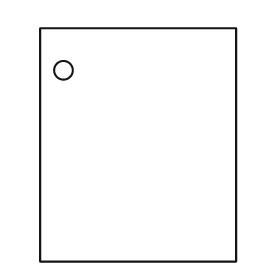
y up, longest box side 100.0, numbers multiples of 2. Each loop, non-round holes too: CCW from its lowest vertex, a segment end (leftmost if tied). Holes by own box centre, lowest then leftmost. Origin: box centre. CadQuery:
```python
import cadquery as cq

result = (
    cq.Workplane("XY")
    .moveTo(-42.0, -50.0)
    .lineTo(42.0, -50.0)
    .lineTo(42.0, 50.0)
    .lineTo(-42.0, 50.0)
    .close()
    .moveTo(-32.0, 32.0)
    .circle(4.0)
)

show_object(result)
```